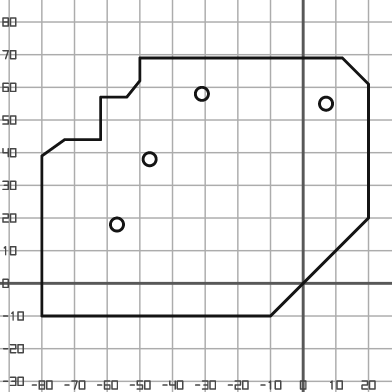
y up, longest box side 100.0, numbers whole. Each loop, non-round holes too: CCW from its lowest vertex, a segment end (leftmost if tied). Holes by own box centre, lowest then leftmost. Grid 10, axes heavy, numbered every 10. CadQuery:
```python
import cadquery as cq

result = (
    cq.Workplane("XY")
    .moveTo(-80.0, -10.0)
    .lineTo(-10.0, -10.0)
    .lineTo(20.0, 20.0)
    .lineTo(20.0, 61.0)
    .lineTo(12.0, 69.0)
    .lineTo(-50.0, 69.0)
    .lineTo(-50.0, 62.0)
    .lineTo(-54.0, 57.0)
    .lineTo(-62.0, 57.0)
    .lineTo(-62.0, 44.0)
    .lineTo(-73.0, 44.0)
    .lineTo(-80.0, 39.0)
    .close()
    .moveTo(-57.0, 18.0)
    .circle(2.0)
    .moveTo(-47.0, 38.0)
    .circle(2.0)
    .moveTo(7.0, 55.0)
    .circle(2.0)
    .moveTo(-31.0, 58.0)
    .circle(2.0)
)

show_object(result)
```